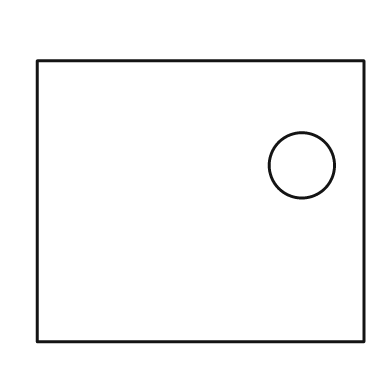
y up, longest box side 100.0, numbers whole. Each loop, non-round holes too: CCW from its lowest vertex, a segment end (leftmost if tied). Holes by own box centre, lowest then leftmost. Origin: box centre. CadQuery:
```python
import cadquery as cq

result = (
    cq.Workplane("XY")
    .moveTo(-50.0, -43.0)
    .lineTo(50.0, -43.0)
    .lineTo(50.0, 43.0)
    .lineTo(-50.0, 43.0)
    .close()
    .moveTo(31.0, 11.0)
    .circle(10.0)
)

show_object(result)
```